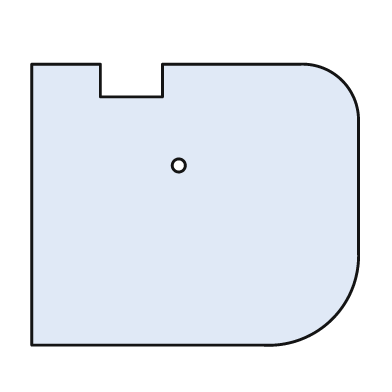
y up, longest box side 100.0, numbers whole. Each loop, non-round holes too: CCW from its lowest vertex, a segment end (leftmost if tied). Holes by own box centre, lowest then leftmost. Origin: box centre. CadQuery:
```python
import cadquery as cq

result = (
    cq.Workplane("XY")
    .moveTo(-50.0, -43.0)
    .lineTo(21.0, -43.0)
    .threePointArc((42.0, -35.0), (50.0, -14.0))
    .lineTo(50.0, 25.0)
    .threePointArc((45.0, 38.0), (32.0, 43.0))
    .lineTo(-10.0, 43.0)
    .lineTo(-10.0, 33.0)
    .lineTo(-29.0, 33.0)
    .lineTo(-29.0, 43.0)
    .lineTo(-50.0, 43.0)
    .close()
    .moveTo(-5.0, 12.0)
    .circle(2.0)
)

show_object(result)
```